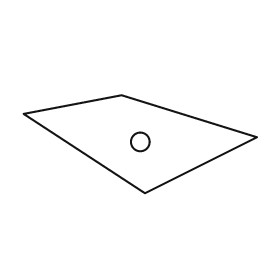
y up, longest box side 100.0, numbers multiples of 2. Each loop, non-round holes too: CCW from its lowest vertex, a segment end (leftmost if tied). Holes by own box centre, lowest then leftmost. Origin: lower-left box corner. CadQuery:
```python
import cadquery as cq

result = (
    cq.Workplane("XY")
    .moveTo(52.0, 0.0)
    .lineTo(100.0, 24.0)
    .lineTo(42.0, 42.0)
    .lineTo(0.0, 34.0)
    .close()
    .moveTo(50.0, 22.0)
    .circle(4.0)
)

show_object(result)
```